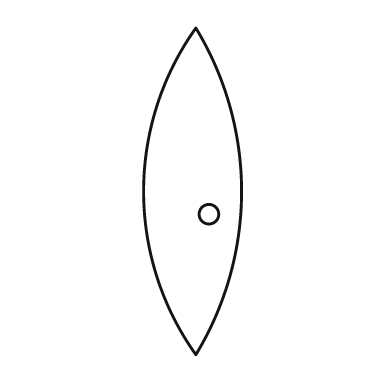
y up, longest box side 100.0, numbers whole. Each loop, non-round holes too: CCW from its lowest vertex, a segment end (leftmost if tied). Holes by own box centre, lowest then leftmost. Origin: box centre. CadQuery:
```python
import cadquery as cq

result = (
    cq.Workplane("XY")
    .moveTo(1.0, -50.0)
    .threePointArc((15.0, 0.0), (1.0, 50.0))
    .threePointArc((-15.0, 0.0), (1.0, -50.0))
    .close()
    .moveTo(5.0, -7.0)
    .circle(3.0)
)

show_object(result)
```